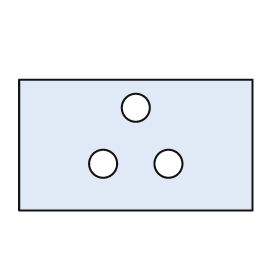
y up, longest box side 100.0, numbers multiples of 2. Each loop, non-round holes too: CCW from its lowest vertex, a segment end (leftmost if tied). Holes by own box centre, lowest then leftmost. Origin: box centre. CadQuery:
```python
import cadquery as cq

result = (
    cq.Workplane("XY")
    .moveTo(-50.0, -28.0)
    .lineTo(50.0, -28.0)
    .lineTo(50.0, 28.0)
    .lineTo(-50.0, 28.0)
    .close()
    .moveTo(-14.0, -8.0)
    .circle(6.0)
    .moveTo(14.0, -8.0)
    .circle(6.0)
    .moveTo(0.0, 16.0)
    .circle(6.0)
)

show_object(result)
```